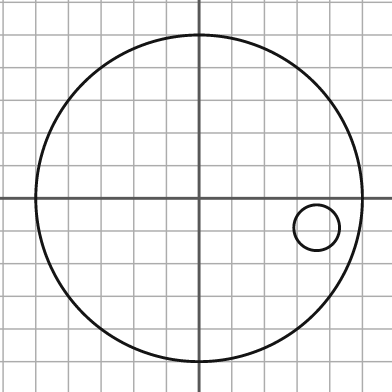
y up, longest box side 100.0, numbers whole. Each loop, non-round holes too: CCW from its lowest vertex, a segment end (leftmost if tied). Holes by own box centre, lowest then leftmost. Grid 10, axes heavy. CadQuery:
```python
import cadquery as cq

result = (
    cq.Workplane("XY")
    .moveTo(0.0, 0.0)
    .circle(50.0)
    .moveTo(36.0, -9.0)
    .circle(7.0)
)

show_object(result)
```